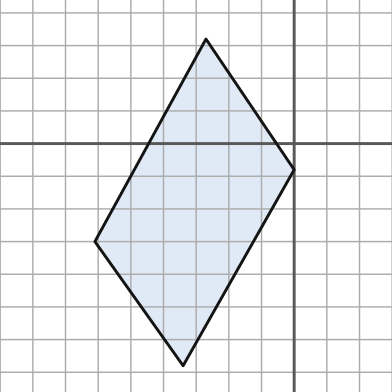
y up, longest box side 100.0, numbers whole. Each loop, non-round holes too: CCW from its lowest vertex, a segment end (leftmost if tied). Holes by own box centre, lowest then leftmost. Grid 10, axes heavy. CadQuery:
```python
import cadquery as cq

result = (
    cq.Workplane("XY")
    .moveTo(-34.0, -68.0)
    .lineTo(0.0, -8.0)
    .lineTo(-27.0, 32.0)
    .lineTo(-61.0, -30.0)
    .close()
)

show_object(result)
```